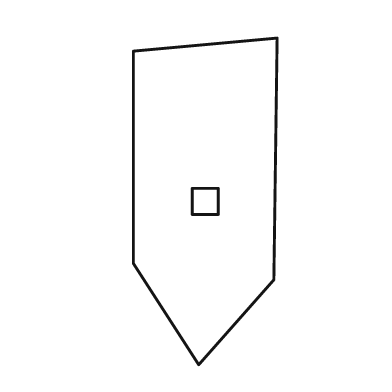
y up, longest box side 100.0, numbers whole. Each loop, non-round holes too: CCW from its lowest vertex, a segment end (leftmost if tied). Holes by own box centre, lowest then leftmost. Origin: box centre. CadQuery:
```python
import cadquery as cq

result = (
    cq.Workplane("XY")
    .moveTo(-2.0, -50.0)
    .lineTo(21.0, -24.0)
    .lineTo(22.0, 50.0)
    .lineTo(-22.0, 46.0)
    .lineTo(-22.0, -19.0)
    .close()
    .moveTo(-4.0, -4.0)
    .lineTo(4.0, -4.0)
    .lineTo(4.0, 4.0)
    .lineTo(-4.0, 4.0)
    .close()
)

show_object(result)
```